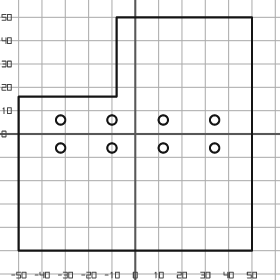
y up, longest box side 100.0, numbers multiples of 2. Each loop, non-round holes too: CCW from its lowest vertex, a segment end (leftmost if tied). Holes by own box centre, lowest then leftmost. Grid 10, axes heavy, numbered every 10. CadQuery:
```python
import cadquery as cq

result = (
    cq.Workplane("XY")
    .moveTo(-50.0, -50.0)
    .lineTo(50.0, -50.0)
    .lineTo(50.0, 50.0)
    .lineTo(-8.0, 50.0)
    .lineTo(-8.0, 16.0)
    .lineTo(-50.0, 16.0)
    .close()
    .moveTo(-32.0, -6.0)
    .circle(2.0)
    .moveTo(-10.0, -6.0)
    .circle(2.0)
    .moveTo(12.0, -6.0)
    .circle(2.0)
    .moveTo(34.0, -6.0)
    .circle(2.0)
    .moveTo(-32.0, 6.0)
    .circle(2.0)
    .moveTo(-10.0, 6.0)
    .circle(2.0)
    .moveTo(12.0, 6.0)
    .circle(2.0)
    .moveTo(34.0, 6.0)
    .circle(2.0)
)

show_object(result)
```